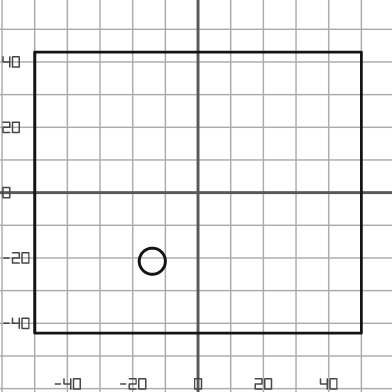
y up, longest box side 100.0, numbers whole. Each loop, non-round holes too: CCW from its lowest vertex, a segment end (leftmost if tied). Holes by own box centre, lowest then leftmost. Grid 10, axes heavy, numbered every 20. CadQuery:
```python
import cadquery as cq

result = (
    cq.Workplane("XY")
    .moveTo(-50.0, -43.0)
    .lineTo(50.0, -43.0)
    .lineTo(50.0, 43.0)
    .lineTo(-50.0, 43.0)
    .close()
    .moveTo(-14.0, -21.0)
    .circle(4.0)
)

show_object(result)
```